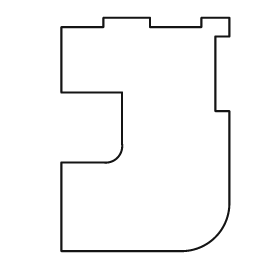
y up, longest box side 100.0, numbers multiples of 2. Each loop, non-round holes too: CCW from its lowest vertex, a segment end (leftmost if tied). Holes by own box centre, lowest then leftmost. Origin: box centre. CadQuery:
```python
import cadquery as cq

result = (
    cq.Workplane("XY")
    .moveTo(-36.0, -50.0)
    .lineTo(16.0, -50.0)
    .threePointArc((30.0, -44.0), (36.0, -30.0))
    .lineTo(36.0, 10.0)
    .lineTo(30.0, 10.0)
    .lineTo(30.0, 42.0)
    .lineTo(36.0, 42.0)
    .lineTo(36.0, 50.0)
    .lineTo(24.0, 50.0)
    .lineTo(24.0, 46.0)
    .lineTo(2.0, 46.0)
    .lineTo(2.0, 50.0)
    .lineTo(-18.0, 50.0)
    .lineTo(-18.0, 46.0)
    .lineTo(-36.0, 46.0)
    .lineTo(-36.0, 18.0)
    .lineTo(-10.0, 18.0)
    .lineTo(-10.0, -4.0)
    .threePointArc((-12.0, -10.0), (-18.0, -12.0))
    .lineTo(-36.0, -12.0)
    .close()
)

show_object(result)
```